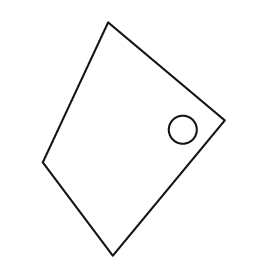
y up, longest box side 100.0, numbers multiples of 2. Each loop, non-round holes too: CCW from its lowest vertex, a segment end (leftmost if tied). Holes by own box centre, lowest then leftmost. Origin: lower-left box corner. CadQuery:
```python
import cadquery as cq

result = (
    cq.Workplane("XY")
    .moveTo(30.0, 0.0)
    .lineTo(78.0, 58.0)
    .lineTo(28.0, 100.0)
    .lineTo(0.0, 40.0)
    .close()
    .moveTo(60.0, 54.0)
    .circle(6.0)
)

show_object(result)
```